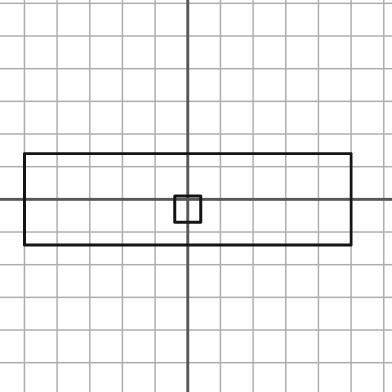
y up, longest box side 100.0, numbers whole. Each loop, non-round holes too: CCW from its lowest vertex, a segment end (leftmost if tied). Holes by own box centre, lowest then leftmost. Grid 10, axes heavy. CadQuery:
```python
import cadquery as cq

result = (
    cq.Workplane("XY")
    .moveTo(-50.0, -14.0)
    .lineTo(50.0, -14.0)
    .lineTo(50.0, 14.0)
    .lineTo(-50.0, 14.0)
    .close()
    .moveTo(-4.0, -7.0)
    .lineTo(4.0, -7.0)
    .lineTo(4.0, 1.0)
    .lineTo(-4.0, 1.0)
    .close()
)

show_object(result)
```